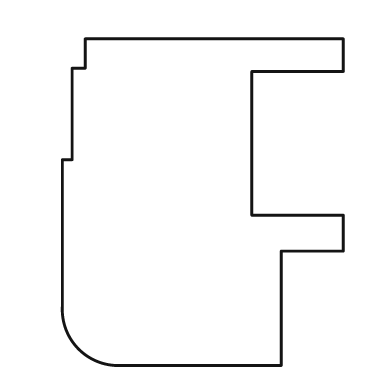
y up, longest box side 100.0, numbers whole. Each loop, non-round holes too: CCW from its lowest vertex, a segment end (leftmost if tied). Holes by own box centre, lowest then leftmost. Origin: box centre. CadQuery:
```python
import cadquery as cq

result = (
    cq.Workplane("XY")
    .moveTo(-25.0, -50.0)
    .lineTo(24.0, -50.0)
    .lineTo(24.0, -15.0)
    .lineTo(43.0, -15.0)
    .lineTo(43.0, -4.0)
    .lineTo(15.0, -4.0)
    .lineTo(15.0, 40.0)
    .lineTo(43.0, 40.0)
    .lineTo(43.0, 50.0)
    .lineTo(-36.0, 50.0)
    .lineTo(-36.0, 41.0)
    .lineTo(-40.0, 41.0)
    .lineTo(-40.0, 13.0)
    .lineTo(-43.0, 13.0)
    .lineTo(-43.0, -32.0)
    .threePointArc((-38.0, -45.0), (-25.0, -50.0))
    .close()
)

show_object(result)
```